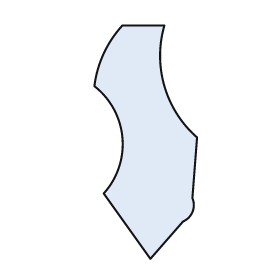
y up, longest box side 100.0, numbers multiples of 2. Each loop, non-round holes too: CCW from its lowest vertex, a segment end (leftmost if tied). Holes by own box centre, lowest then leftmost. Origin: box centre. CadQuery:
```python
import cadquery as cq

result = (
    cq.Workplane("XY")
    .moveTo(2.0, -50.0)
    .lineTo(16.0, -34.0)
    .threePointArc((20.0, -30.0), (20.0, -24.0))
    .lineTo(22.0, 2.0)
    .threePointArc((8.0, 24.0), (8.0, 50.0))
    .lineTo(-10.0, 50.0)
    .threePointArc((-18.0, 38.0), (-22.0, 24.0))
    .threePointArc((-10.0, 2.0), (-18.0, -22.0))
    .close()
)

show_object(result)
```